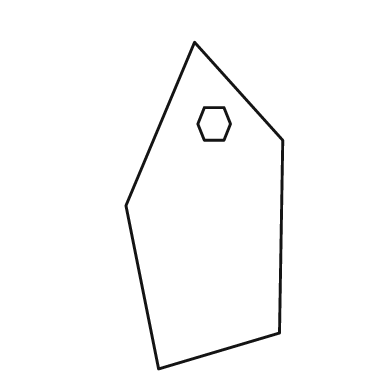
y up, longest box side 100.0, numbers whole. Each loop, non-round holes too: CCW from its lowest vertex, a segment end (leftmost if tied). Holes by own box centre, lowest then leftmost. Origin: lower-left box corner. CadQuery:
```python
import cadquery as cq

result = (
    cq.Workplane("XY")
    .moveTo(10.0, 0.0)
    .lineTo(47.0, 11.0)
    .lineTo(48.0, 70.0)
    .lineTo(21.0, 100.0)
    .lineTo(0.0, 50.0)
    .close()
    .moveTo(24.0, 70.0)
    .lineTo(30.0, 70.0)
    .lineTo(32.0, 75.0)
    .lineTo(30.0, 80.0)
    .lineTo(24.0, 80.0)
    .lineTo(22.0, 75.0)
    .close()
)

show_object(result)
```